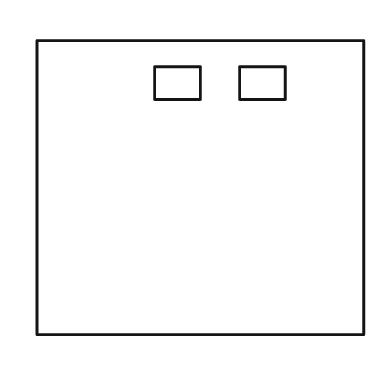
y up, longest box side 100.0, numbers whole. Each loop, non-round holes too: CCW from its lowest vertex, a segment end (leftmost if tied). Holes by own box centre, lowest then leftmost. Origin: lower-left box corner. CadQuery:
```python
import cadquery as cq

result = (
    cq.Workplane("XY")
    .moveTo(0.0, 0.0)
    .lineTo(100.0, 0.0)
    .lineTo(100.0, 90.0)
    .lineTo(0.0, 90.0)
    .close()
    .moveTo(36.0, 72.0)
    .lineTo(50.0, 72.0)
    .lineTo(50.0, 82.0)
    .lineTo(36.0, 82.0)
    .close()
    .moveTo(62.0, 72.0)
    .lineTo(76.0, 72.0)
    .lineTo(76.0, 82.0)
    .lineTo(62.0, 82.0)
    .close()
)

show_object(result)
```